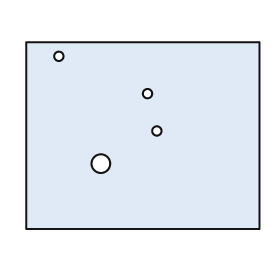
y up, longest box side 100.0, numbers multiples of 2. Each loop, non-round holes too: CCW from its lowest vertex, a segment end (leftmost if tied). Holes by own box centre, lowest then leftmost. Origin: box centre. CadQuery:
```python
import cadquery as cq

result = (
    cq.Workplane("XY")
    .moveTo(-50.0, -40.0)
    .lineTo(50.0, -40.0)
    .lineTo(50.0, 40.0)
    .lineTo(-50.0, 40.0)
    .close()
    .moveTo(-18.0, -12.0)
    .circle(4.0)
    .moveTo(6.0, 2.0)
    .circle(2.0)
    .moveTo(2.0, 18.0)
    .circle(2.0)
    .moveTo(-36.0, 34.0)
    .circle(2.0)
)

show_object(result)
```